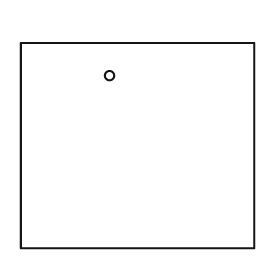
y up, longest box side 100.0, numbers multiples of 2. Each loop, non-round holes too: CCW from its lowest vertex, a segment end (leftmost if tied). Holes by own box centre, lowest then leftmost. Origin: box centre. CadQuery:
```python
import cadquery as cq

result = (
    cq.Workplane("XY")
    .moveTo(-50.0, -44.0)
    .lineTo(50.0, -44.0)
    .lineTo(50.0, 44.0)
    .lineTo(-50.0, 44.0)
    .close()
    .moveTo(-12.0, 30.0)
    .circle(2.0)
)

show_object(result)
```